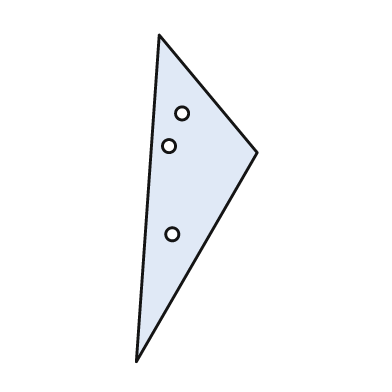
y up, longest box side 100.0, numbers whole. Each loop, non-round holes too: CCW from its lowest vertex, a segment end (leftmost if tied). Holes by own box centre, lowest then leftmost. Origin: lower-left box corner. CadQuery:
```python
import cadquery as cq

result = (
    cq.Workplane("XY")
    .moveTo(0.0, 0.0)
    .lineTo(37.0, 64.0)
    .lineTo(7.0, 100.0)
    .close()
    .moveTo(11.0, 39.0)
    .circle(2.0)
    .moveTo(10.0, 66.0)
    .circle(2.0)
    .moveTo(14.0, 76.0)
    .circle(2.0)
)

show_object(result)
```